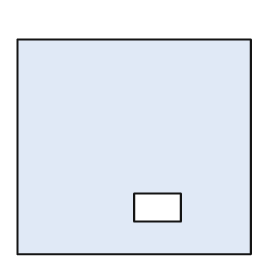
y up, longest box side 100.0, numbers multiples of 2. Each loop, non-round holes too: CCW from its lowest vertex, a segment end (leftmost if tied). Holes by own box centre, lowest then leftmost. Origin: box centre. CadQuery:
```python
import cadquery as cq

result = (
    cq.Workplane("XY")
    .moveTo(-50.0, -46.0)
    .lineTo(50.0, -46.0)
    .lineTo(50.0, 46.0)
    .lineTo(-50.0, 46.0)
    .close()
    .moveTo(0.0, -32.0)
    .lineTo(20.0, -32.0)
    .lineTo(20.0, -20.0)
    .lineTo(0.0, -20.0)
    .close()
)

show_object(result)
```